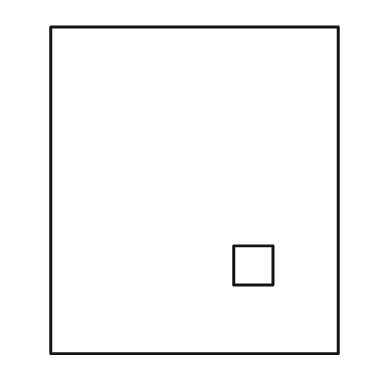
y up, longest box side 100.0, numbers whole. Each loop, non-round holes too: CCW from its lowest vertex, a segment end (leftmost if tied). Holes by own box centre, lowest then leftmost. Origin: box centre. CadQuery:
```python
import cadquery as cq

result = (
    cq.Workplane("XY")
    .moveTo(-44.0, -50.0)
    .lineTo(44.0, -50.0)
    .lineTo(44.0, 50.0)
    .lineTo(-44.0, 50.0)
    .close()
    .moveTo(12.0, -29.0)
    .lineTo(24.0, -29.0)
    .lineTo(24.0, -17.0)
    .lineTo(12.0, -17.0)
    .close()
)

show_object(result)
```